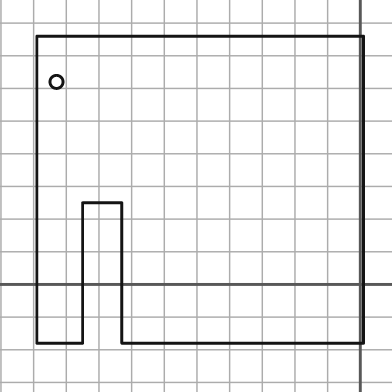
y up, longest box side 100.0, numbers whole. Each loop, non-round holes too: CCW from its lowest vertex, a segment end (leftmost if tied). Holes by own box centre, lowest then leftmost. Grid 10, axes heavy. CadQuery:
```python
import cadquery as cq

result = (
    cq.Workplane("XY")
    .moveTo(-99.0, -18.0)
    .lineTo(-85.0, -18.0)
    .lineTo(-85.0, 25.0)
    .lineTo(-73.0, 25.0)
    .lineTo(-73.0, -18.0)
    .lineTo(1.0, -18.0)
    .lineTo(1.0, 76.0)
    .lineTo(-99.0, 76.0)
    .close()
    .moveTo(-93.0, 62.0)
    .circle(2.0)
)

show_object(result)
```